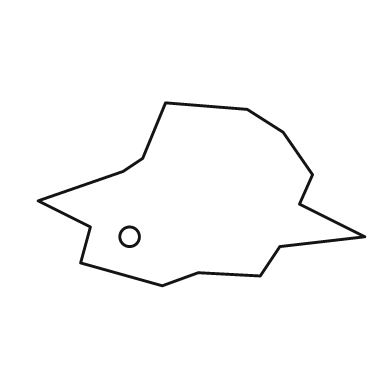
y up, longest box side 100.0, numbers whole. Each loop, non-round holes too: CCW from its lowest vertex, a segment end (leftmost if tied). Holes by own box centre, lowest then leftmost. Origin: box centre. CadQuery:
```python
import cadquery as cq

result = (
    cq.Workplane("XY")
    .moveTo(-12.0, -28.0)
    .lineTo(-1.0, -24.0)
    .lineTo(18.0, -25.0)
    .lineTo(24.0, -16.0)
    .lineTo(50.0, -13.0)
    .lineTo(30.0, -3.0)
    .lineTo(34.0, 6.0)
    .lineTo(25.0, 19.0)
    .lineTo(14.0, 26.0)
    .lineTo(-11.0, 28.0)
    .lineTo(-18.0, 11.0)
    .lineTo(-24.0, 7.0)
    .lineTo(-50.0, -2.0)
    .lineTo(-34.0, -10.0)
    .lineTo(-37.0, -21.0)
    .close()
    .moveTo(-22.0, -13.0)
    .circle(3.0)
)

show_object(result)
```